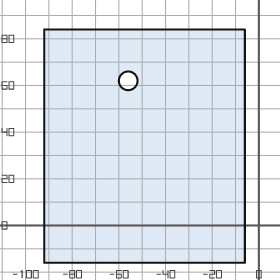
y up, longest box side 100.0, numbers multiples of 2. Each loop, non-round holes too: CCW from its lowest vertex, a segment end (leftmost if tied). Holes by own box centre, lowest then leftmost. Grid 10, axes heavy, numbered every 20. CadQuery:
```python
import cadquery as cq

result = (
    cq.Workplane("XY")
    .moveTo(-92.0, -16.0)
    .lineTo(-6.0, -16.0)
    .lineTo(-6.0, 84.0)
    .lineTo(-92.0, 84.0)
    .close()
    .moveTo(-56.0, 62.0)
    .circle(4.0)
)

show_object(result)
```